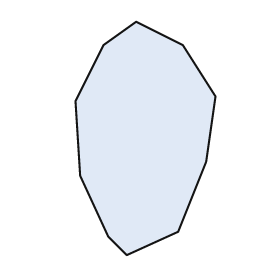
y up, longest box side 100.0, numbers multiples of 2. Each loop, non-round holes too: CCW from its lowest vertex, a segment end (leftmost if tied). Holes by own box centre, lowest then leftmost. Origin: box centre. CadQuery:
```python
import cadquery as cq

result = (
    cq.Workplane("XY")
    .moveTo(-8.0, -50.0)
    .lineTo(14.0, -40.0)
    .lineTo(26.0, -10.0)
    .lineTo(30.0, 18.0)
    .lineTo(16.0, 40.0)
    .lineTo(-4.0, 50.0)
    .lineTo(-18.0, 40.0)
    .lineTo(-30.0, 16.0)
    .lineTo(-28.0, -16.0)
    .lineTo(-16.0, -42.0)
    .close()
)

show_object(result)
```